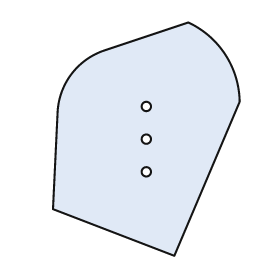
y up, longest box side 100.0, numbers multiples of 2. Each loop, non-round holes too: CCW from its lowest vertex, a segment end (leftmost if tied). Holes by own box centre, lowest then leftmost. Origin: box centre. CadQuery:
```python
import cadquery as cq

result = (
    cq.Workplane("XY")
    .moveTo(12.0, -50.0)
    .lineTo(40.0, 16.0)
    .threePointArc((34.0, 36.0), (18.0, 50.0))
    .lineTo(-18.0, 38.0)
    .threePointArc((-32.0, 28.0), (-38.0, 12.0))
    .lineTo(-40.0, -30.0)
    .close()
    .moveTo(0.0, -14.0)
    .circle(2.0)
    .moveTo(0.0, 0.0)
    .circle(2.0)
    .moveTo(0.0, 14.0)
    .circle(2.0)
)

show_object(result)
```